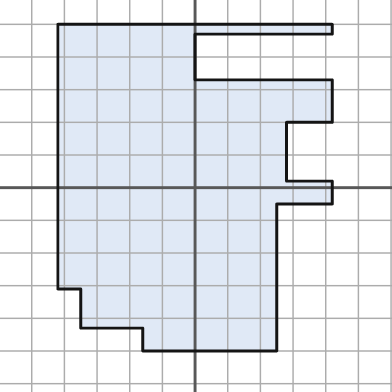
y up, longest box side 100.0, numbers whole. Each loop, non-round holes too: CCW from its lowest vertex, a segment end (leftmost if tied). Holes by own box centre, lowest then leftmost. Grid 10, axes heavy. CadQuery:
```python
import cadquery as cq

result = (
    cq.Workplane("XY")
    .moveTo(-16.0, -50.0)
    .lineTo(25.0, -50.0)
    .lineTo(25.0, -5.0)
    .lineTo(42.0, -5.0)
    .lineTo(42.0, 2.0)
    .lineTo(28.0, 2.0)
    .lineTo(28.0, 20.0)
    .lineTo(42.0, 20.0)
    .lineTo(42.0, 33.0)
    .lineTo(0.0, 33.0)
    .lineTo(0.0, 47.0)
    .lineTo(42.0, 47.0)
    .lineTo(42.0, 50.0)
    .lineTo(-42.0, 50.0)
    .lineTo(-42.0, -31.0)
    .lineTo(-35.0, -31.0)
    .lineTo(-35.0, -43.0)
    .lineTo(-16.0, -43.0)
    .close()
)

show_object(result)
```